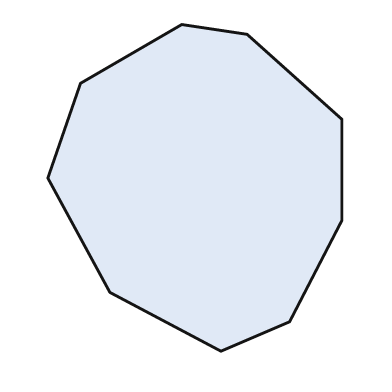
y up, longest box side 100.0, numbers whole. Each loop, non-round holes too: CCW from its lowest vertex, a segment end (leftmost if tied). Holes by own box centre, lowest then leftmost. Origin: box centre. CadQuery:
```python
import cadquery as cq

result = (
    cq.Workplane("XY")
    .moveTo(8.0, -50.0)
    .lineTo(29.0, -41.0)
    .lineTo(45.0, -10.0)
    .lineTo(45.0, 21.0)
    .lineTo(16.0, 47.0)
    .lineTo(-4.0, 50.0)
    .lineTo(-35.0, 32.0)
    .lineTo(-45.0, 3.0)
    .lineTo(-26.0, -32.0)
    .close()
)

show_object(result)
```